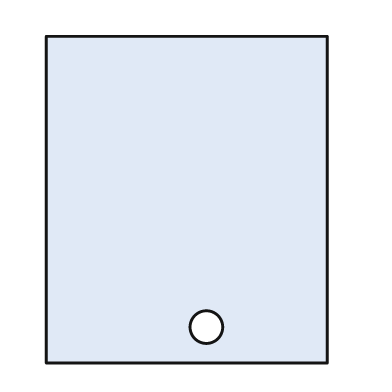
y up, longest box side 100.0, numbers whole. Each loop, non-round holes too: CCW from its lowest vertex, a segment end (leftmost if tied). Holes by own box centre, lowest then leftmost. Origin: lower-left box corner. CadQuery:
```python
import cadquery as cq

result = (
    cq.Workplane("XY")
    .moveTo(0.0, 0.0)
    .lineTo(86.0, 0.0)
    .lineTo(86.0, 100.0)
    .lineTo(0.0, 100.0)
    .close()
    .moveTo(49.0, 11.0)
    .circle(5.0)
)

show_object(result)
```